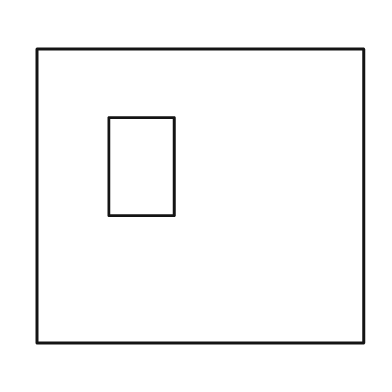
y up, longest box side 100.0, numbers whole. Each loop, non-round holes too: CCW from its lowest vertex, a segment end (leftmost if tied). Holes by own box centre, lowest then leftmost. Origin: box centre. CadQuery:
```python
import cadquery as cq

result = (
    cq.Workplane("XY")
    .moveTo(-50.0, -45.0)
    .lineTo(50.0, -45.0)
    .lineTo(50.0, 45.0)
    .lineTo(-50.0, 45.0)
    .close()
    .moveTo(-28.0, -6.0)
    .lineTo(-8.0, -6.0)
    .lineTo(-8.0, 24.0)
    .lineTo(-28.0, 24.0)
    .close()
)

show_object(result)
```